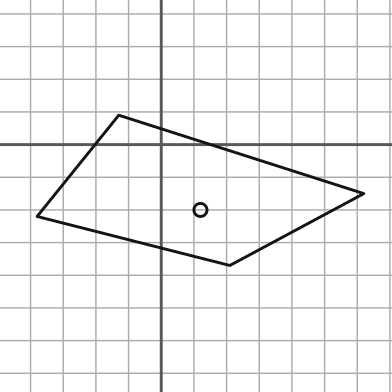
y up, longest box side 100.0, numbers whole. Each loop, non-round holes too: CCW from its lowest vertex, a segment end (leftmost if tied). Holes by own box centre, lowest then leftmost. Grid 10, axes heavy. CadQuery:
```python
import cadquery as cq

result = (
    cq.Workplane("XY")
    .moveTo(21.0, -37.0)
    .lineTo(62.0, -15.0)
    .lineTo(-13.0, 9.0)
    .lineTo(-38.0, -22.0)
    .close()
    .moveTo(12.0, -20.0)
    .circle(2.0)
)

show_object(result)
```